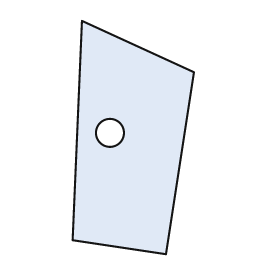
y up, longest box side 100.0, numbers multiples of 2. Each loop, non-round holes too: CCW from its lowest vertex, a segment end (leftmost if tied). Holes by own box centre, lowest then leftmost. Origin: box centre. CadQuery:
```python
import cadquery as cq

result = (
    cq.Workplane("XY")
    .moveTo(14.0, -50.0)
    .lineTo(26.0, 28.0)
    .lineTo(-22.0, 50.0)
    .lineTo(-26.0, -44.0)
    .close()
    .moveTo(-10.0, 2.0)
    .circle(6.0)
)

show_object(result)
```